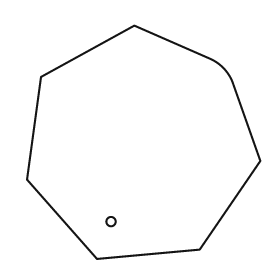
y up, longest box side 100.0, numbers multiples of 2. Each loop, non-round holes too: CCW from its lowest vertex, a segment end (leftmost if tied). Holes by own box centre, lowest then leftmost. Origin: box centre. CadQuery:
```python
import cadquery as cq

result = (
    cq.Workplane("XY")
    .moveTo(-20.0, -50.0)
    .lineTo(24.0, -46.0)
    .lineTo(50.0, -8.0)
    .lineTo(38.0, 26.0)
    .threePointArc((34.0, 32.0), (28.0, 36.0))
    .lineTo(-4.0, 50.0)
    .lineTo(-44.0, 28.0)
    .lineTo(-50.0, -16.0)
    .close()
    .moveTo(-14.0, -34.0)
    .circle(2.0)
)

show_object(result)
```